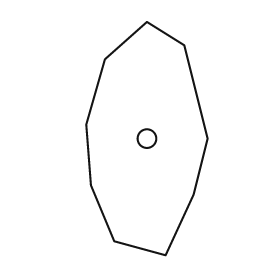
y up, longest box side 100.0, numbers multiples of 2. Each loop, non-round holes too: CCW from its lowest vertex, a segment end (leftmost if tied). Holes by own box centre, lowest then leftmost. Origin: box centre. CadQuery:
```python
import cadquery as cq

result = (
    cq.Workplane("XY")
    .moveTo(8.0, -50.0)
    .lineTo(20.0, -24.0)
    .lineTo(26.0, 0.0)
    .lineTo(16.0, 40.0)
    .lineTo(0.0, 50.0)
    .lineTo(-18.0, 34.0)
    .lineTo(-26.0, 6.0)
    .lineTo(-24.0, -20.0)
    .lineTo(-14.0, -44.0)
    .close()
    .moveTo(0.0, 0.0)
    .circle(4.0)
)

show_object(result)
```